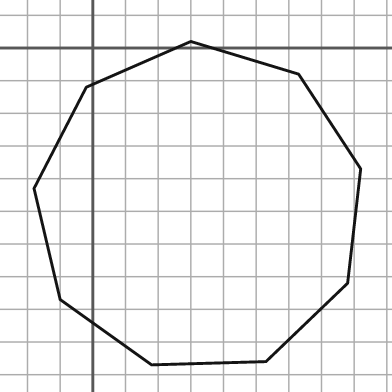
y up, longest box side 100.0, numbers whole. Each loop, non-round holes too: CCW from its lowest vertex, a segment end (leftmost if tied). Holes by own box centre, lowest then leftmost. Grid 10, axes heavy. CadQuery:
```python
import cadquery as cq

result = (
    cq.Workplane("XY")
    .moveTo(18.0, -97.0)
    .lineTo(53.0, -96.0)
    .lineTo(78.0, -72.0)
    .lineTo(82.0, -37.0)
    .lineTo(63.0, -8.0)
    .lineTo(30.0, 2.0)
    .lineTo(-2.0, -12.0)
    .lineTo(-18.0, -43.0)
    .lineTo(-10.0, -77.0)
    .close()
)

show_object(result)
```